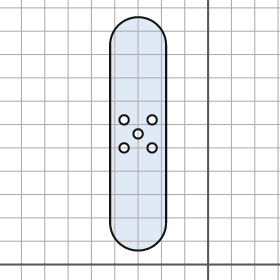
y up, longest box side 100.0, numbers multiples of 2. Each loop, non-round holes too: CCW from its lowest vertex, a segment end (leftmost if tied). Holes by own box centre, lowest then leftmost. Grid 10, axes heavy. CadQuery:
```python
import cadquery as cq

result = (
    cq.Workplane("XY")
    .moveTo(-42.0, 18.0)
    .threePointArc((-30.0, 6.0), (-18.0, 18.0))
    .lineTo(-18.0, 94.0)
    .threePointArc((-30.0, 106.0), (-42.0, 94.0))
    .close()
    .moveTo(-36.0, 50.0)
    .circle(2.0)
    .moveTo(-24.0, 50.0)
    .circle(2.0)
    .moveTo(-30.0, 56.0)
    .circle(2.0)
    .moveTo(-36.0, 62.0)
    .circle(2.0)
    .moveTo(-24.0, 62.0)
    .circle(2.0)
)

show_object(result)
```